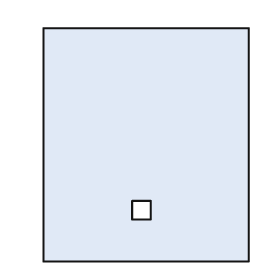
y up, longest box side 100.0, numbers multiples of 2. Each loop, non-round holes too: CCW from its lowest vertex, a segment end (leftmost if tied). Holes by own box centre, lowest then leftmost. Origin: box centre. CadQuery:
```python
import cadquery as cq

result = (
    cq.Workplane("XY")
    .moveTo(-44.0, -50.0)
    .lineTo(44.0, -50.0)
    .lineTo(44.0, 50.0)
    .lineTo(-44.0, 50.0)
    .close()
    .moveTo(-6.0, -32.0)
    .lineTo(2.0, -32.0)
    .lineTo(2.0, -24.0)
    .lineTo(-6.0, -24.0)
    .close()
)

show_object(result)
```